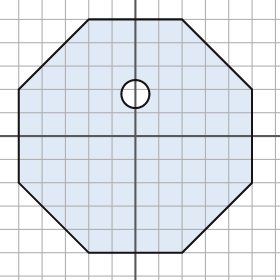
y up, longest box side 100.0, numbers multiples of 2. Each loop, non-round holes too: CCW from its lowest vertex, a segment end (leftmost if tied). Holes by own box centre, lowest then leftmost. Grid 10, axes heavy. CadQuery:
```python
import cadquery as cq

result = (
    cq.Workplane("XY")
    .moveTo(-20.0, -50.0)
    .lineTo(20.0, -50.0)
    .lineTo(50.0, -20.0)
    .lineTo(50.0, 20.0)
    .lineTo(20.0, 50.0)
    .lineTo(-20.0, 50.0)
    .lineTo(-50.0, 20.0)
    .lineTo(-50.0, -20.0)
    .close()
    .moveTo(0.0, 18.0)
    .circle(6.0)
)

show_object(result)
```